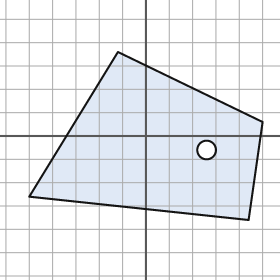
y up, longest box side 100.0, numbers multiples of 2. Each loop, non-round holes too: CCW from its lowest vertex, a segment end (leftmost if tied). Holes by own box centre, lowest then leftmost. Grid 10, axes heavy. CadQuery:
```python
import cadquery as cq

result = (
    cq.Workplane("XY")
    .moveTo(44.0, -36.0)
    .lineTo(50.0, 6.0)
    .lineTo(-12.0, 36.0)
    .lineTo(-50.0, -26.0)
    .close()
    .moveTo(26.0, -6.0)
    .circle(4.0)
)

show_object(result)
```